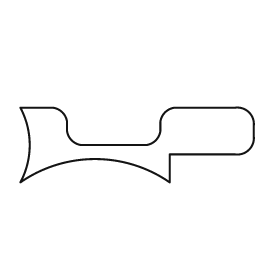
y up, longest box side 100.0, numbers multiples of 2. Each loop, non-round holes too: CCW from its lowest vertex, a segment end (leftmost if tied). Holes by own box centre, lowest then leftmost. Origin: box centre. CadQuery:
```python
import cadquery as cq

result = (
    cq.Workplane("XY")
    .moveTo(-50.0, -16.0)
    .threePointArc((-18.0, -6.0), (14.0, -16.0))
    .lineTo(14.0, -4.0)
    .lineTo(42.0, -4.0)
    .threePointArc((48.0, -2.0), (50.0, 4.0))
    .lineTo(50.0, 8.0)
    .threePointArc((48.0, 14.0), (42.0, 16.0))
    .lineTo(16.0, 16.0)
    .threePointArc((12.0, 14.0), (10.0, 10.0))
    .lineTo(10.0, 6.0)
    .threePointArc((8.0, 2.0), (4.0, 0.0))
    .lineTo(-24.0, 0.0)
    .threePointArc((-28.0, 2.0), (-30.0, 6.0))
    .lineTo(-30.0, 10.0)
    .threePointArc((-32.0, 14.0), (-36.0, 16.0))
    .lineTo(-50.0, 16.0)
    .threePointArc((-46.0, 0.0), (-50.0, -16.0))
    .close()
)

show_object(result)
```